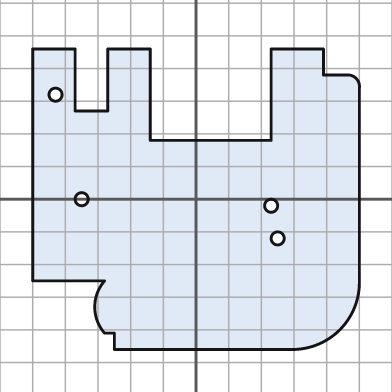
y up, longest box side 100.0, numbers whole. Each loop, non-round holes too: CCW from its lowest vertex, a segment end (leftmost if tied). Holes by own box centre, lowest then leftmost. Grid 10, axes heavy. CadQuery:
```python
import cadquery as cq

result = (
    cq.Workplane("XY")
    .moveTo(-25.0, -46.0)
    .lineTo(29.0, -46.0)
    .threePointArc((44.0, -40.0), (50.0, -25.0))
    .lineTo(50.0, 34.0)
    .threePointArc((49.0, 37.0), (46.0, 38.0))
    .lineTo(39.0, 38.0)
    .lineTo(39.0, 46.0)
    .lineTo(23.0, 46.0)
    .lineTo(23.0, 18.0)
    .lineTo(-14.0, 18.0)
    .lineTo(-14.0, 46.0)
    .lineTo(-27.0, 46.0)
    .lineTo(-27.0, 27.0)
    .lineTo(-37.0, 27.0)
    .lineTo(-37.0, 46.0)
    .lineTo(-50.0, 46.0)
    .lineTo(-50.0, -25.0)
    .lineTo(-28.0, -25.0)
    .threePointArc((-31.0, -33.0), (-28.0, -41.0))
    .lineTo(-25.0, -41.0)
    .close()
    .moveTo(25.0, -12.0)
    .circle(2.0)
    .moveTo(23.0, -2.0)
    .circle(2.0)
    .moveTo(-35.0, 0.0)
    .circle(2.0)
    .moveTo(-43.0, 32.0)
    .circle(2.0)
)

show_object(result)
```